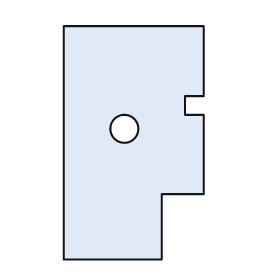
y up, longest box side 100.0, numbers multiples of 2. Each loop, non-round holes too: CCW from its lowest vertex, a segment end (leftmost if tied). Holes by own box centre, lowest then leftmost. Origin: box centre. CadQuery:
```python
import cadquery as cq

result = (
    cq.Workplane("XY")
    .moveTo(-30.0, -50.0)
    .lineTo(12.0, -50.0)
    .lineTo(12.0, -22.0)
    .lineTo(30.0, -22.0)
    .lineTo(30.0, 12.0)
    .lineTo(22.0, 12.0)
    .lineTo(22.0, 20.0)
    .lineTo(30.0, 20.0)
    .lineTo(30.0, 50.0)
    .lineTo(-30.0, 50.0)
    .close()
    .moveTo(-4.0, 6.0)
    .circle(6.0)
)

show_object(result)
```